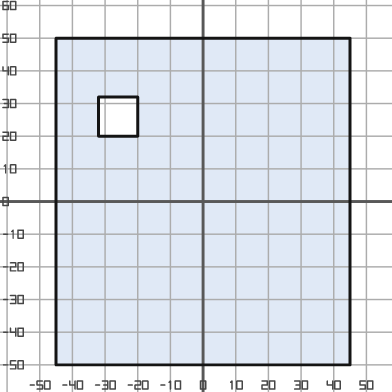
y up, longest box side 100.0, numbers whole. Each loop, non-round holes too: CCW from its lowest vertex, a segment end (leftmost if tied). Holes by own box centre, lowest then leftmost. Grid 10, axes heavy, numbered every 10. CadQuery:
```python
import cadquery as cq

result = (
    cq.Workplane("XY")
    .moveTo(-45.0, -50.0)
    .lineTo(45.0, -50.0)
    .lineTo(45.0, 50.0)
    .lineTo(-45.0, 50.0)
    .close()
    .moveTo(-32.0, 20.0)
    .lineTo(-20.0, 20.0)
    .lineTo(-20.0, 32.0)
    .lineTo(-32.0, 32.0)
    .close()
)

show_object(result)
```